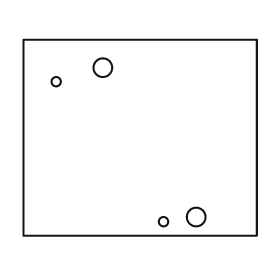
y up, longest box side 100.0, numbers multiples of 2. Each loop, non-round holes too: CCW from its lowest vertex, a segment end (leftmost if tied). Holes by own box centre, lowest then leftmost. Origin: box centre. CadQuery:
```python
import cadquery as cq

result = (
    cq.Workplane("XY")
    .moveTo(-50.0, -42.0)
    .lineTo(50.0, -42.0)
    .lineTo(50.0, 42.0)
    .lineTo(-50.0, 42.0)
    .close()
    .moveTo(10.0, -36.0)
    .circle(2.0)
    .moveTo(24.0, -34.0)
    .circle(4.0)
    .moveTo(-36.0, 24.0)
    .circle(2.0)
    .moveTo(-16.0, 30.0)
    .circle(4.0)
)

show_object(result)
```